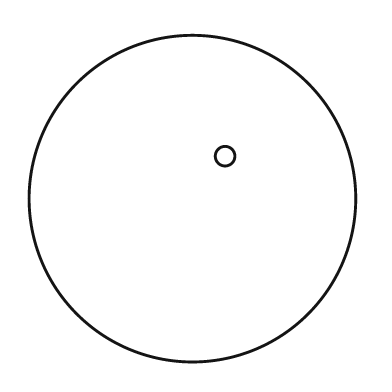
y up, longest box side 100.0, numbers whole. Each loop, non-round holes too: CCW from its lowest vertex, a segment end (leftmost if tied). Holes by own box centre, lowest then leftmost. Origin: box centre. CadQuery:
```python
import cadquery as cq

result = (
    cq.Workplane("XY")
    .moveTo(0.0, 0.0)
    .circle(50.0)
    .moveTo(10.0, 13.0)
    .circle(3.0)
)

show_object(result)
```